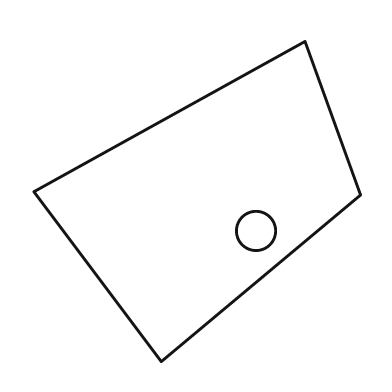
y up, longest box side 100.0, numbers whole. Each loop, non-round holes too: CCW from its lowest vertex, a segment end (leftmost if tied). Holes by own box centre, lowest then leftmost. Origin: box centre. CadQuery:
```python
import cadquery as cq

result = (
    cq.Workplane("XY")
    .moveTo(-11.0, -49.0)
    .lineTo(50.0, 2.0)
    .lineTo(33.0, 49.0)
    .lineTo(-50.0, 3.0)
    .close()
    .moveTo(18.0, -9.0)
    .circle(6.0)
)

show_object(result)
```